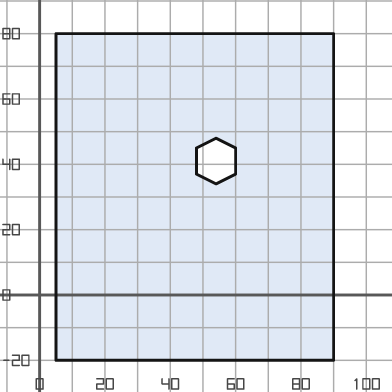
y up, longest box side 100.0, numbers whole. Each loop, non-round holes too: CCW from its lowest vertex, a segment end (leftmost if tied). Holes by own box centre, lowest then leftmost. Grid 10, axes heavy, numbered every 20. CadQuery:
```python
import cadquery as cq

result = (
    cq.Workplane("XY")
    .moveTo(5.0, -20.0)
    .lineTo(90.0, -20.0)
    .lineTo(90.0, 80.0)
    .lineTo(5.0, 80.0)
    .close()
    .moveTo(54.0, 34.0)
    .lineTo(60.0, 37.0)
    .lineTo(60.0, 45.0)
    .lineTo(54.0, 48.0)
    .lineTo(48.0, 45.0)
    .lineTo(48.0, 37.0)
    .close()
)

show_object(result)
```